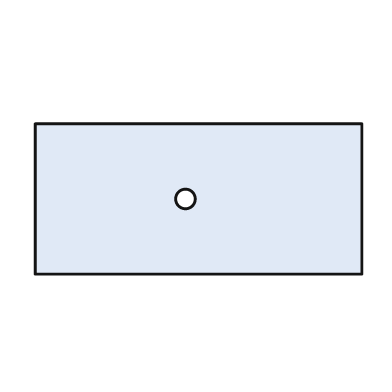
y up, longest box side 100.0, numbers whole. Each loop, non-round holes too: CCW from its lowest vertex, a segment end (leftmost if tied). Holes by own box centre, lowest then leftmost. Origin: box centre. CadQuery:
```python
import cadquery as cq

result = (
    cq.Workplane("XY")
    .moveTo(-50.0, -23.0)
    .lineTo(50.0, -23.0)
    .lineTo(50.0, 23.0)
    .lineTo(-50.0, 23.0)
    .close()
    .moveTo(-4.0, 0.0)
    .circle(3.0)
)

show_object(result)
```